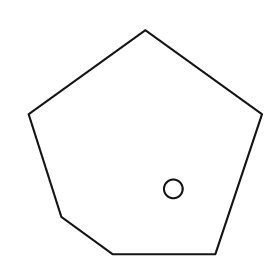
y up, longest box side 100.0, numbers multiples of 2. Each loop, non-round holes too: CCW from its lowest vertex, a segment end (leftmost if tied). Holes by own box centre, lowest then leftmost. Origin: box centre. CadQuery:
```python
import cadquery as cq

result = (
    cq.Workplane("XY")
    .moveTo(-14.0, -48.0)
    .lineTo(30.0, -48.0)
    .lineTo(50.0, 12.0)
    .lineTo(0.0, 48.0)
    .lineTo(-50.0, 12.0)
    .lineTo(-36.0, -32.0)
    .close()
    .moveTo(12.0, -20.0)
    .circle(4.0)
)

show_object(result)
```